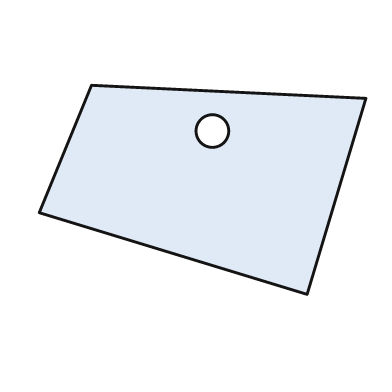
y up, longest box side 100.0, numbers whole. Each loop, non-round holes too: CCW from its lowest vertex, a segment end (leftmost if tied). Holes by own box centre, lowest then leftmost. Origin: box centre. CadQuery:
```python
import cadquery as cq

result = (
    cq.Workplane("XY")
    .moveTo(32.0, -32.0)
    .lineTo(50.0, 28.0)
    .lineTo(-34.0, 32.0)
    .lineTo(-50.0, -7.0)
    .close()
    .moveTo(3.0, 18.0)
    .circle(5.0)
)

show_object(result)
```